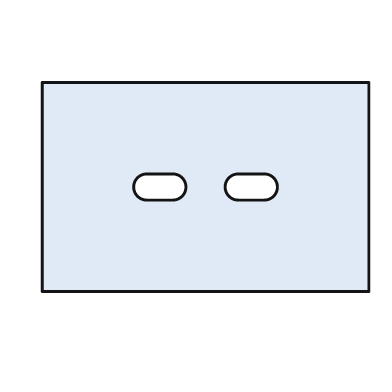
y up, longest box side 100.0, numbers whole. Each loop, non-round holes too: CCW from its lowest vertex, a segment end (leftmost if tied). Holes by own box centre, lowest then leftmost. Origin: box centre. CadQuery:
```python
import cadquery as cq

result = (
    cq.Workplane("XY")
    .moveTo(-50.0, -32.0)
    .lineTo(50.0, -32.0)
    .lineTo(50.0, 32.0)
    .lineTo(-50.0, 32.0)
    .close()
    .moveTo(-18.0, -4.0)
    .lineTo(-10.0, -4.0)
    .threePointArc((-6.0, 0.0), (-10.0, 4.0))
    .lineTo(-18.0, 4.0)
    .threePointArc((-22.0, 0.0), (-18.0, -4.0))
    .close()
    .moveTo(10.0, -4.0)
    .lineTo(18.0, -4.0)
    .threePointArc((22.0, 0.0), (18.0, 4.0))
    .lineTo(10.0, 4.0)
    .threePointArc((6.0, 0.0), (10.0, -4.0))
    .close()
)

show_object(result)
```